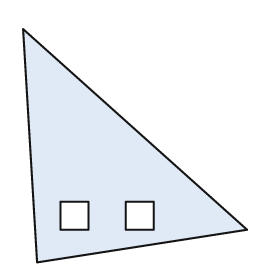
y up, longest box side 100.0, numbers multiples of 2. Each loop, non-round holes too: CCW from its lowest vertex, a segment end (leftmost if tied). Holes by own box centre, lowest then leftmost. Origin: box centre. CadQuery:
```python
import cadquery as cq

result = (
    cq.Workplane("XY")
    .moveTo(-42.0, -50.0)
    .lineTo(48.0, -36.0)
    .lineTo(-48.0, 50.0)
    .close()
    .moveTo(-32.0, -36.0)
    .lineTo(-20.0, -36.0)
    .lineTo(-20.0, -24.0)
    .lineTo(-32.0, -24.0)
    .close()
    .moveTo(-4.0, -36.0)
    .lineTo(8.0, -36.0)
    .lineTo(8.0, -24.0)
    .lineTo(-4.0, -24.0)
    .close()
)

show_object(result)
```